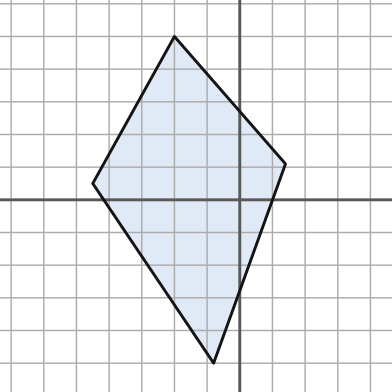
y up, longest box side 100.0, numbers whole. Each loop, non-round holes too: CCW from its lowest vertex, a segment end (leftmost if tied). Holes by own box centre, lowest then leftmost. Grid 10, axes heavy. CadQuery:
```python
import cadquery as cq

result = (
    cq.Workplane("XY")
    .moveTo(-8.0, -50.0)
    .lineTo(14.0, 11.0)
    .lineTo(-20.0, 50.0)
    .lineTo(-45.0, 5.0)
    .close()
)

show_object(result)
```